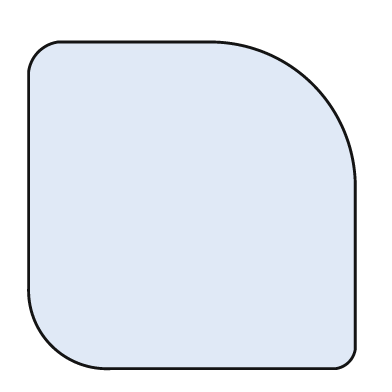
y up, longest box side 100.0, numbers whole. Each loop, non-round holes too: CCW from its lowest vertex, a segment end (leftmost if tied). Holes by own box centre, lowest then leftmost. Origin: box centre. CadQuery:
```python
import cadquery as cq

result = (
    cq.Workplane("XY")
    .moveTo(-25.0, -50.0)
    .lineTo(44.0, -50.0)
    .threePointArc((48.0, -48.0), (50.0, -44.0))
    .lineTo(50.0, 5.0)
    .threePointArc((37.0, 37.0), (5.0, 50.0))
    .lineTo(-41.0, 50.0)
    .threePointArc((-47.0, 47.0), (-50.0, 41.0))
    .lineTo(-50.0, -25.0)
    .threePointArc((-43.0, -43.0), (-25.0, -50.0))
    .close()
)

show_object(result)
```